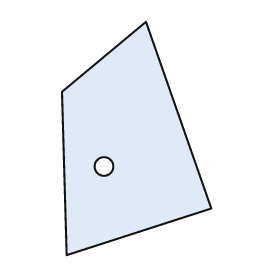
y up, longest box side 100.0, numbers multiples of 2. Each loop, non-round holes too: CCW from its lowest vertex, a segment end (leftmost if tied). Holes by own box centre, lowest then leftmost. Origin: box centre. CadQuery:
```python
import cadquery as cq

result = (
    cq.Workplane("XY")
    .moveTo(-30.0, -50.0)
    .lineTo(32.0, -30.0)
    .lineTo(4.0, 50.0)
    .lineTo(-32.0, 20.0)
    .close()
    .moveTo(-14.0, -12.0)
    .circle(4.0)
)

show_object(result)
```